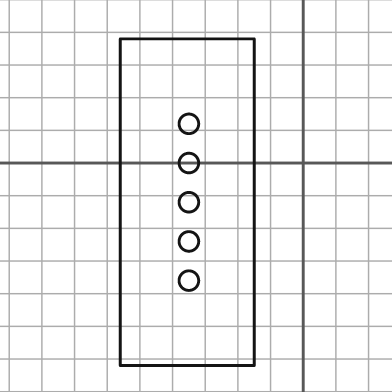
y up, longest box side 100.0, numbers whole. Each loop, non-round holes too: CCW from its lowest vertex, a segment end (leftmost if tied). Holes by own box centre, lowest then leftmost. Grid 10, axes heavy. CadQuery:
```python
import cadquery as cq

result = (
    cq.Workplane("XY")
    .moveTo(-56.0, -62.0)
    .lineTo(-15.0, -62.0)
    .lineTo(-15.0, 38.0)
    .lineTo(-56.0, 38.0)
    .close()
    .moveTo(-35.0, -36.0)
    .circle(3.0)
    .moveTo(-35.0, -24.0)
    .circle(3.0)
    .moveTo(-35.0, -12.0)
    .circle(3.0)
    .moveTo(-35.0, 0.0)
    .circle(3.0)
    .moveTo(-35.0, 12.0)
    .circle(3.0)
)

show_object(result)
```